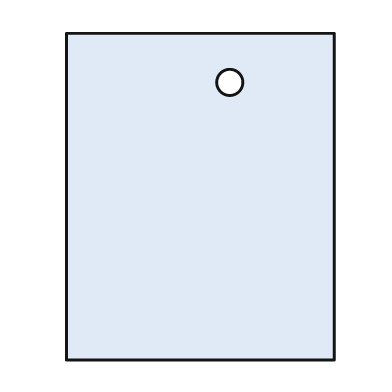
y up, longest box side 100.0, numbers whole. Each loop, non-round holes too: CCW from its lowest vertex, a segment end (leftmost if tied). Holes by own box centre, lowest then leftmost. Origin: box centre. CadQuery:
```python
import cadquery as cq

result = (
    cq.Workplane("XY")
    .moveTo(-41.0, -50.0)
    .lineTo(41.0, -50.0)
    .lineTo(41.0, 50.0)
    .lineTo(-41.0, 50.0)
    .close()
    .moveTo(9.0, 35.0)
    .circle(4.0)
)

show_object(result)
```